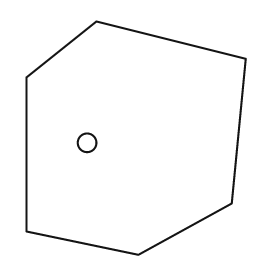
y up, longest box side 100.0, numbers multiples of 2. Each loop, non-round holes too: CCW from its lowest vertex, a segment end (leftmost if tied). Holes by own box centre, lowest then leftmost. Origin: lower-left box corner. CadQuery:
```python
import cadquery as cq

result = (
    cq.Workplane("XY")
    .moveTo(48.0, 0.0)
    .lineTo(88.0, 22.0)
    .lineTo(94.0, 84.0)
    .lineTo(30.0, 100.0)
    .lineTo(0.0, 76.0)
    .lineTo(0.0, 10.0)
    .close()
    .moveTo(26.0, 48.0)
    .circle(4.0)
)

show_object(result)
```